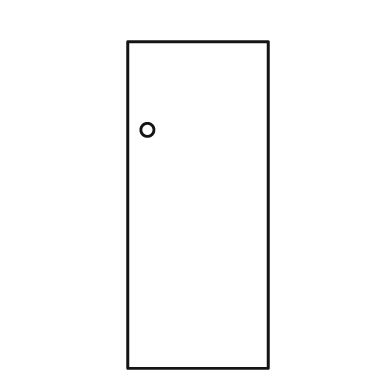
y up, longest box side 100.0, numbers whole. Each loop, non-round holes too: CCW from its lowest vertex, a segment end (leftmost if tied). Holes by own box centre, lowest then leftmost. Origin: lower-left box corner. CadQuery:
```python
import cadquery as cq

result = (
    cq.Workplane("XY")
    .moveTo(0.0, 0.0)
    .lineTo(43.0, 0.0)
    .lineTo(43.0, 100.0)
    .lineTo(0.0, 100.0)
    .close()
    .moveTo(6.0, 73.0)
    .circle(2.0)
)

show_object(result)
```